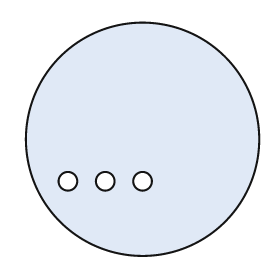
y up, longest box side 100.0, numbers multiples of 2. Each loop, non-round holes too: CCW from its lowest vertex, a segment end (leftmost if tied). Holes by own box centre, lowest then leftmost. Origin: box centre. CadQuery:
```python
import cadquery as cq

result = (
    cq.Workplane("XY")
    .moveTo(0.0, 0.0)
    .circle(50.0)
    .moveTo(-32.0, -18.0)
    .circle(4.0)
    .moveTo(-16.0, -18.0)
    .circle(4.0)
    .moveTo(0.0, -18.0)
    .circle(4.0)
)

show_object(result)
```